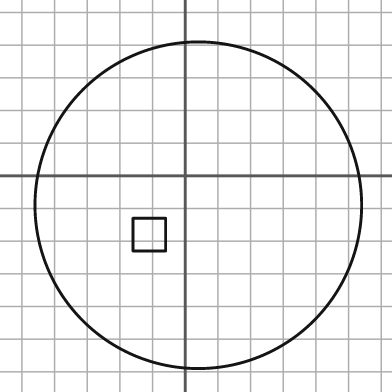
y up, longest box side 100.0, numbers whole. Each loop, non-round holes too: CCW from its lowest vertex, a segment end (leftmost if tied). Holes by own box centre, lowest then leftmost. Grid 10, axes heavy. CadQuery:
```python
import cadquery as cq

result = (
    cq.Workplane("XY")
    .moveTo(4.0, -9.0)
    .circle(50.0)
    .moveTo(-16.0, -23.0)
    .lineTo(-6.0, -23.0)
    .lineTo(-6.0, -13.0)
    .lineTo(-16.0, -13.0)
    .close()
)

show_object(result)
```